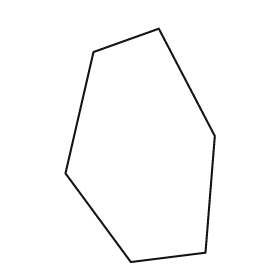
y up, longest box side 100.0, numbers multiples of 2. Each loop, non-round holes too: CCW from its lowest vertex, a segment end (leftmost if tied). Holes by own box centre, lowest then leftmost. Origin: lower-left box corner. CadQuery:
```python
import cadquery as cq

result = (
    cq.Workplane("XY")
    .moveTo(28.0, 0.0)
    .lineTo(60.0, 4.0)
    .lineTo(64.0, 54.0)
    .lineTo(40.0, 100.0)
    .lineTo(12.0, 90.0)
    .lineTo(0.0, 38.0)
    .close()
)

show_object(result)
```